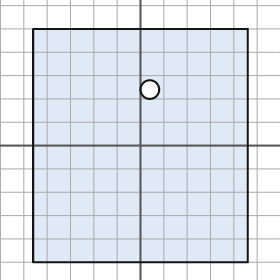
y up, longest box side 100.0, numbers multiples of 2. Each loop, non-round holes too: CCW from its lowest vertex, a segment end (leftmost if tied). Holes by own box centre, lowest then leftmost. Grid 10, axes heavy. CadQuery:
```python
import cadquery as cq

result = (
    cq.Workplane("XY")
    .moveTo(-46.0, -50.0)
    .lineTo(46.0, -50.0)
    .lineTo(46.0, 50.0)
    .lineTo(-46.0, 50.0)
    .close()
    .moveTo(4.0, 24.0)
    .circle(4.0)
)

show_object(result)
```